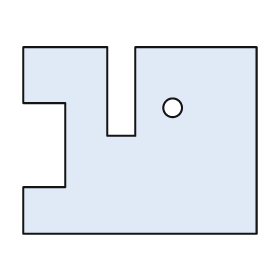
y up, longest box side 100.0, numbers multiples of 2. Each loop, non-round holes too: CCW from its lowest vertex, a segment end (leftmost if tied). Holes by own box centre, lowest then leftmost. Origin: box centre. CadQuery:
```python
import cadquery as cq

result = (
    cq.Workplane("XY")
    .moveTo(-50.0, -40.0)
    .lineTo(50.0, -40.0)
    .lineTo(50.0, 40.0)
    .lineTo(-2.0, 40.0)
    .lineTo(-2.0, 2.0)
    .lineTo(-14.0, 2.0)
    .lineTo(-14.0, 40.0)
    .lineTo(-50.0, 40.0)
    .lineTo(-50.0, 16.0)
    .lineTo(-32.0, 16.0)
    .lineTo(-32.0, -20.0)
    .lineTo(-50.0, -20.0)
    .close()
    .moveTo(14.0, 14.0)
    .circle(4.0)
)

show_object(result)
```